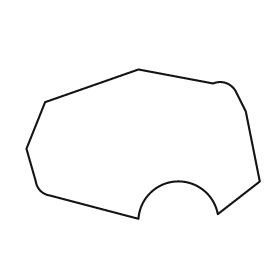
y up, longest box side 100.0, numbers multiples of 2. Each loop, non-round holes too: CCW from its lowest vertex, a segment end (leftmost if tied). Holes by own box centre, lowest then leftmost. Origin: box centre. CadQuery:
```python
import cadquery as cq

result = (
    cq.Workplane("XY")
    .moveTo(-2.0, -32.0)
    .threePointArc((14.0, -16.0), (32.0, -30.0))
    .lineTo(50.0, -16.0)
    .lineTo(44.0, 14.0)
    .lineTo(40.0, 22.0)
    .threePointArc((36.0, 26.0), (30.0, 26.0))
    .lineTo(-2.0, 32.0)
    .lineTo(-42.0, 18.0)
    .lineTo(-50.0, -2.0)
    .lineTo(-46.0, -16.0)
    .threePointArc((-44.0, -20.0), (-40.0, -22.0))
    .close()
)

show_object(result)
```